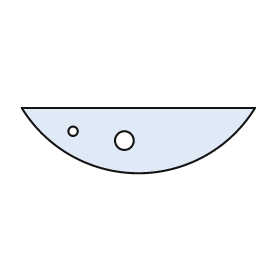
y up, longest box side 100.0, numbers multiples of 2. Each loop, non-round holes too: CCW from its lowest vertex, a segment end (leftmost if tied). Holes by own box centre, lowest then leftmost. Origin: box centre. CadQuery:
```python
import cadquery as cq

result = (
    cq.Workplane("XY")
    .moveTo(-50.0, 14.0)
    .threePointArc((0.0, -14.0), (50.0, 14.0))
    .close()
    .moveTo(-6.0, 0.0)
    .circle(4.0)
    .moveTo(-28.0, 4.0)
    .circle(2.0)
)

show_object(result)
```